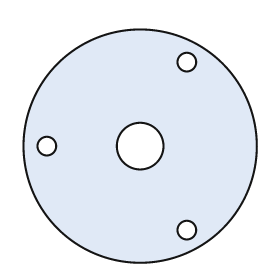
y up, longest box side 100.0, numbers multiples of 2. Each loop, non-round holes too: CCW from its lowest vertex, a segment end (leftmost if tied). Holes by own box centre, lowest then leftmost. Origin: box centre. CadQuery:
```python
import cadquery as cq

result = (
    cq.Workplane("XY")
    .moveTo(0.0, 0.0)
    .circle(50.0)
    .moveTo(20.0, -36.0)
    .circle(4.0)
    .moveTo(-40.0, 0.0)
    .circle(4.0)
    .moveTo(0.0, 0.0)
    .circle(10.0)
    .moveTo(20.0, 36.0)
    .circle(4.0)
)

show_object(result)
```